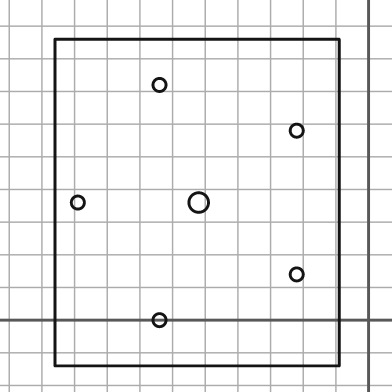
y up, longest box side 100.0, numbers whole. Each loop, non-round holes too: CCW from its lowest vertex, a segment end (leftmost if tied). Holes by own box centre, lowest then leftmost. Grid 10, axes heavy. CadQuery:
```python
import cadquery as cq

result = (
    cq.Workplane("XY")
    .moveTo(-96.0, -14.0)
    .lineTo(-9.0, -14.0)
    .lineTo(-9.0, 86.0)
    .lineTo(-96.0, 86.0)
    .close()
    .moveTo(-64.0, 0.0)
    .circle(2.0)
    .moveTo(-22.0, 14.0)
    .circle(2.0)
    .moveTo(-89.0, 36.0)
    .circle(2.0)
    .moveTo(-52.0, 36.0)
    .circle(3.0)
    .moveTo(-22.0, 58.0)
    .circle(2.0)
    .moveTo(-64.0, 72.0)
    .circle(2.0)
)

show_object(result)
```